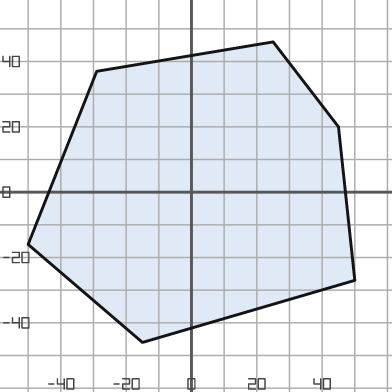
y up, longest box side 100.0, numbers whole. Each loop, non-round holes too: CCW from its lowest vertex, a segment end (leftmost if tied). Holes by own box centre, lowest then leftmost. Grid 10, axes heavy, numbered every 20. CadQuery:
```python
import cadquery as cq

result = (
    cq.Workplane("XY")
    .moveTo(-15.0, -46.0)
    .lineTo(50.0, -27.0)
    .lineTo(45.0, 20.0)
    .lineTo(25.0, 46.0)
    .lineTo(-29.0, 37.0)
    .lineTo(-50.0, -16.0)
    .close()
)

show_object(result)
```